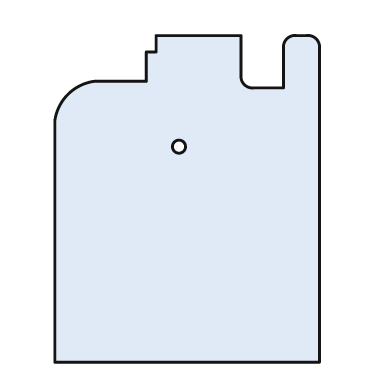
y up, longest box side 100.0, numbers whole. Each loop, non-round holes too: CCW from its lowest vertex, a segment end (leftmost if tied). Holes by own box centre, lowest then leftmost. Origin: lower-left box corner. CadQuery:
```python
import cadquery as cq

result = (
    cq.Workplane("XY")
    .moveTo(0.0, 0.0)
    .lineTo(81.0, 0.0)
    .lineTo(81.0, 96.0)
    .threePointArc((80.0, 99.0), (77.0, 100.0))
    .lineTo(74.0, 100.0)
    .threePointArc((71.0, 99.0), (70.0, 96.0))
    .lineTo(70.0, 84.0)
    .lineTo(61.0, 84.0)
    .threePointArc((58.0, 85.0), (57.0, 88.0))
    .lineTo(57.0, 100.0)
    .lineTo(31.0, 100.0)
    .lineTo(31.0, 95.0)
    .lineTo(28.0, 95.0)
    .lineTo(28.0, 86.0)
    .lineTo(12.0, 86.0)
    .threePointArc((4.0, 82.0), (0.0, 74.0))
    .close()
    .moveTo(38.0, 66.0)
    .circle(2.0)
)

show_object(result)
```